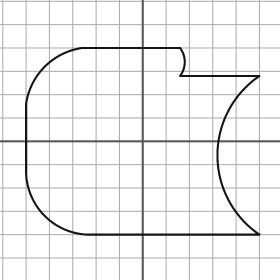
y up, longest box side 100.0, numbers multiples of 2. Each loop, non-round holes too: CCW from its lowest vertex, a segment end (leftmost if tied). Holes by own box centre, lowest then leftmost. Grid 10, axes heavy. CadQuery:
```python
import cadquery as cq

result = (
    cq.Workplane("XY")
    .moveTo(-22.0, -40.0)
    .lineTo(50.0, -40.0)
    .threePointArc((32.0, -6.0), (50.0, 28.0))
    .lineTo(16.0, 28.0)
    .threePointArc((18.0, 34.0), (16.0, 40.0))
    .lineTo(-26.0, 40.0)
    .threePointArc((-42.0, 32.0), (-50.0, 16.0))
    .lineTo(-50.0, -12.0)
    .threePointArc((-42.0, -32.0), (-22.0, -40.0))
    .close()
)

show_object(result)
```